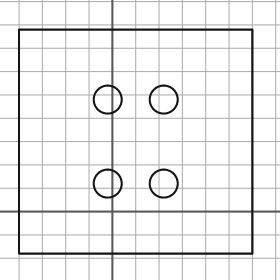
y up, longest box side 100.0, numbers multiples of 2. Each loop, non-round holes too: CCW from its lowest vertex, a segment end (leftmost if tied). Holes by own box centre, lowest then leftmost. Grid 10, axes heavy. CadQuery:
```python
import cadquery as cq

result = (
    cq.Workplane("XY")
    .moveTo(-40.0, -18.0)
    .lineTo(60.0, -18.0)
    .lineTo(60.0, 78.0)
    .lineTo(-40.0, 78.0)
    .close()
    .moveTo(-2.0, 12.0)
    .circle(6.0)
    .moveTo(22.0, 12.0)
    .circle(6.0)
    .moveTo(-2.0, 48.0)
    .circle(6.0)
    .moveTo(22.0, 48.0)
    .circle(6.0)
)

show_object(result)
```